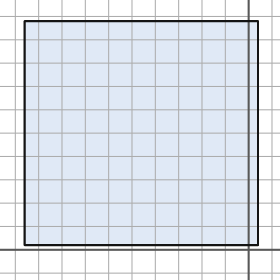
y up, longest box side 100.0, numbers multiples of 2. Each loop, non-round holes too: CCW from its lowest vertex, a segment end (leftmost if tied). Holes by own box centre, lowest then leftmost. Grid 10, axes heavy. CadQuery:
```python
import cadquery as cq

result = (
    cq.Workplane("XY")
    .moveTo(-96.0, 2.0)
    .lineTo(4.0, 2.0)
    .lineTo(4.0, 98.0)
    .lineTo(-96.0, 98.0)
    .close()
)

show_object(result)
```